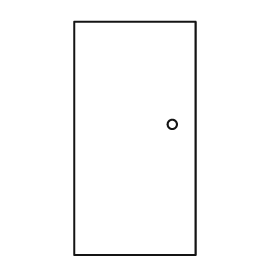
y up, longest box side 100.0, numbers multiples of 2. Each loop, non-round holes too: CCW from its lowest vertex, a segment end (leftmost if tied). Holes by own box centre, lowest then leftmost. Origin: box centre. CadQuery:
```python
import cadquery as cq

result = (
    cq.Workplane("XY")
    .moveTo(-26.0, -50.0)
    .lineTo(26.0, -50.0)
    .lineTo(26.0, 50.0)
    .lineTo(-26.0, 50.0)
    .close()
    .moveTo(16.0, 6.0)
    .circle(2.0)
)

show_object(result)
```